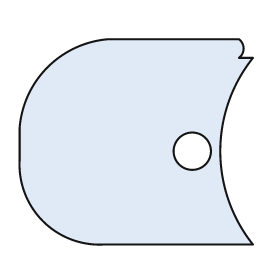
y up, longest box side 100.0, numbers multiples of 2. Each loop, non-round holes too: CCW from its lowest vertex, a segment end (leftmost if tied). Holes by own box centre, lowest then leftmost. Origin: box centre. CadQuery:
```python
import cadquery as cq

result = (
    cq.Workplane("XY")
    .moveTo(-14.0, -44.0)
    .lineTo(50.0, -44.0)
    .threePointArc((36.0, -4.0), (50.0, 36.0))
    .lineTo(44.0, 36.0)
    .threePointArc((46.0, 40.0), (44.0, 44.0))
    .lineTo(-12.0, 44.0)
    .threePointArc((-38.0, 32.0), (-50.0, 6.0))
    .lineTo(-50.0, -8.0)
    .threePointArc((-40.0, -34.0), (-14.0, -44.0))
    .close()
    .moveTo(24.0, -4.0)
    .circle(8.0)
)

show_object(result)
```